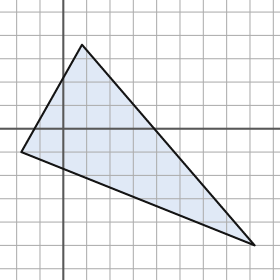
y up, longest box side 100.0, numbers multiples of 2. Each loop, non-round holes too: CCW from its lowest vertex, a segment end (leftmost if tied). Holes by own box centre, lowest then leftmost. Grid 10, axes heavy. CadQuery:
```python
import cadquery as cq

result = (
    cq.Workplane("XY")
    .moveTo(82.0, -50.0)
    .lineTo(8.0, 36.0)
    .lineTo(-18.0, -10.0)
    .close()
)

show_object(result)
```